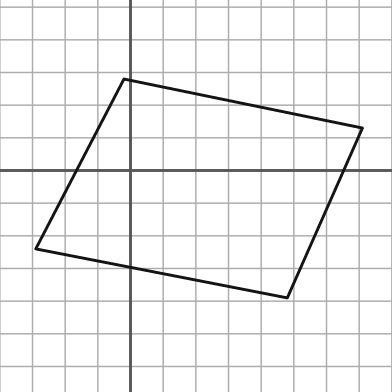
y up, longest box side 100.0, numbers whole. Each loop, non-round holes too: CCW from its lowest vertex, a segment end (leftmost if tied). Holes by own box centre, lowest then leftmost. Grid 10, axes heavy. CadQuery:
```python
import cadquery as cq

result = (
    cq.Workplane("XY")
    .moveTo(48.0, -39.0)
    .lineTo(71.0, 13.0)
    .lineTo(-2.0, 28.0)
    .lineTo(-29.0, -24.0)
    .close()
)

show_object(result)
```